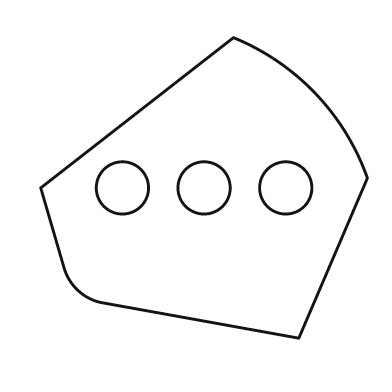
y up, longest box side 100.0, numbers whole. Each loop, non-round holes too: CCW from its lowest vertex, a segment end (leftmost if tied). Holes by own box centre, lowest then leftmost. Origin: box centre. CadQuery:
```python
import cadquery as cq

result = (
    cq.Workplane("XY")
    .moveTo(29.0, -46.0)
    .lineTo(50.0, 3.0)
    .threePointArc((34.0, 29.0), (9.0, 46.0))
    .lineTo(-50.0, 0.0)
    .lineTo(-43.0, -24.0)
    .threePointArc((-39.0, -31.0), (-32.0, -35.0))
    .close()
    .moveTo(-25.0, 0.0)
    .circle(8.0)
    .moveTo(0.0, 0.0)
    .circle(8.0)
    .moveTo(25.0, 0.0)
    .circle(8.0)
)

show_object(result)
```